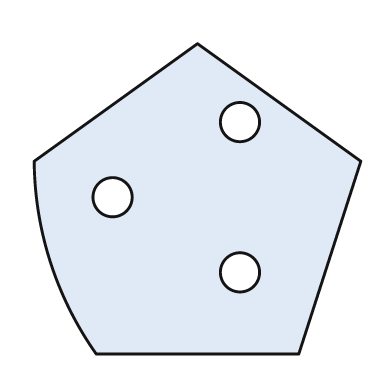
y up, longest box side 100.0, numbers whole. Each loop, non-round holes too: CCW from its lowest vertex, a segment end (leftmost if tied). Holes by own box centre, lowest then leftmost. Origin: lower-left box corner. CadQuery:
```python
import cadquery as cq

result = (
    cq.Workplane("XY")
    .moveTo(19.0, 0.0)
    .lineTo(81.0, 0.0)
    .lineTo(100.0, 59.0)
    .lineTo(50.0, 95.0)
    .lineTo(0.0, 59.0)
    .threePointArc((5.0, 28.0), (19.0, 0.0))
    .close()
    .moveTo(63.0, 25.0)
    .circle(6.0)
    .moveTo(24.0, 48.0)
    .circle(6.0)
    .moveTo(63.0, 71.0)
    .circle(6.0)
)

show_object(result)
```